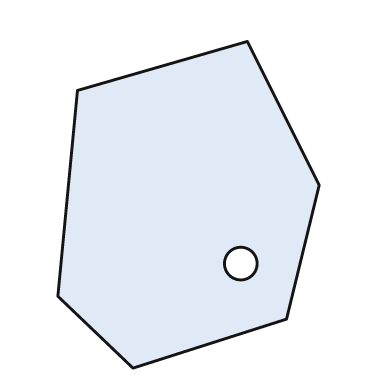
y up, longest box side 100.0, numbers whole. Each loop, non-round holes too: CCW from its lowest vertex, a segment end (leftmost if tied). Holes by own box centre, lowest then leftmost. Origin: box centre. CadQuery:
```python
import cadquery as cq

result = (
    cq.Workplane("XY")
    .moveTo(-17.0, -50.0)
    .lineTo(30.0, -35.0)
    .lineTo(40.0, 6.0)
    .lineTo(18.0, 50.0)
    .lineTo(-34.0, 35.0)
    .lineTo(-40.0, -28.0)
    .close()
    .moveTo(16.0, -18.0)
    .circle(5.0)
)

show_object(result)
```